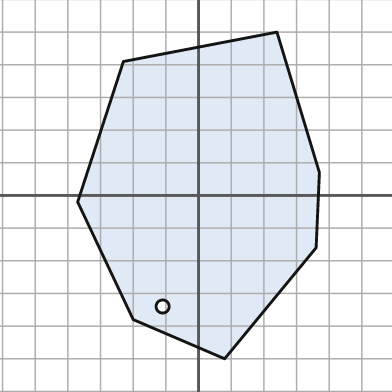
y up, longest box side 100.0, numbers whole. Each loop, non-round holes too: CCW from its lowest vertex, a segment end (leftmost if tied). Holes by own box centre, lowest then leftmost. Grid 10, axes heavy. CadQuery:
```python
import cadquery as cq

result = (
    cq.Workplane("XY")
    .moveTo(8.0, -50.0)
    .lineTo(36.0, -16.0)
    .lineTo(37.0, 7.0)
    .lineTo(24.0, 50.0)
    .lineTo(-23.0, 41.0)
    .lineTo(-37.0, -2.0)
    .lineTo(-20.0, -38.0)
    .close()
    .moveTo(-11.0, -34.0)
    .circle(2.0)
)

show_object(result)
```